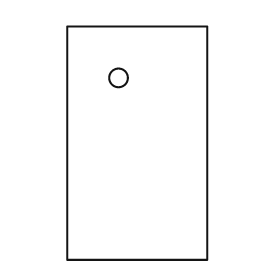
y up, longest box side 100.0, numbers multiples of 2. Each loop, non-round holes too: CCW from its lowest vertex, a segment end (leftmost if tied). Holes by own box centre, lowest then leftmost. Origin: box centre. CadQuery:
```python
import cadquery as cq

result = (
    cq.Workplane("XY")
    .moveTo(-30.0, -50.0)
    .lineTo(30.0, -50.0)
    .lineTo(30.0, 50.0)
    .lineTo(-30.0, 50.0)
    .close()
    .moveTo(-8.0, 28.0)
    .circle(4.0)
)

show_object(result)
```